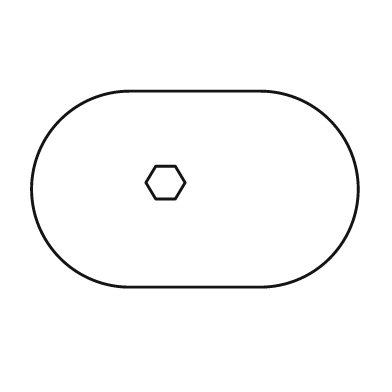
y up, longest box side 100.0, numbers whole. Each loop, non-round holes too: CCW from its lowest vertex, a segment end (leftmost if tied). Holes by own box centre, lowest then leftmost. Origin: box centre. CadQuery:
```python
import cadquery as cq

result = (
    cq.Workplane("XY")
    .moveTo(-20.0, -30.0)
    .lineTo(20.0, -30.0)
    .threePointArc((50.0, 0.0), (20.0, 30.0))
    .lineTo(-20.0, 30.0)
    .threePointArc((-50.0, 0.0), (-20.0, -30.0))
    .close()
    .moveTo(-12.0, -3.0)
    .lineTo(-6.0, -3.0)
    .lineTo(-3.0, 2.0)
    .lineTo(-6.0, 7.0)
    .lineTo(-12.0, 7.0)
    .lineTo(-15.0, 2.0)
    .close()
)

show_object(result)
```